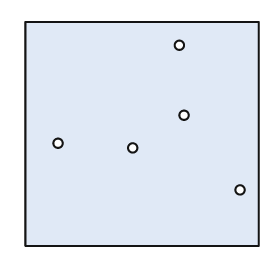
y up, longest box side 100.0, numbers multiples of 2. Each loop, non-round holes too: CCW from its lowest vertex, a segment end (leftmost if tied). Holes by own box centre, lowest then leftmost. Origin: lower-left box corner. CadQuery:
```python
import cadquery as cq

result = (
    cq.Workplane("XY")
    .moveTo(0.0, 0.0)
    .lineTo(100.0, 0.0)
    .lineTo(100.0, 96.0)
    .lineTo(0.0, 96.0)
    .close()
    .moveTo(92.0, 24.0)
    .circle(2.0)
    .moveTo(46.0, 42.0)
    .circle(2.0)
    .moveTo(14.0, 44.0)
    .circle(2.0)
    .moveTo(68.0, 56.0)
    .circle(2.0)
    .moveTo(66.0, 86.0)
    .circle(2.0)
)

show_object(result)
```